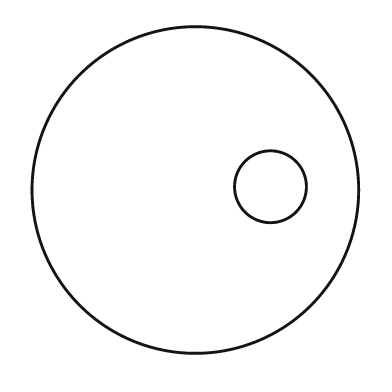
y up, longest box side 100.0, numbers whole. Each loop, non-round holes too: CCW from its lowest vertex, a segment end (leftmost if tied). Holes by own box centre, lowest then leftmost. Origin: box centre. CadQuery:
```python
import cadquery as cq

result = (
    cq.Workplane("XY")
    .moveTo(0.0, 0.0)
    .circle(50.0)
    .moveTo(23.0, 1.0)
    .circle(11.0)
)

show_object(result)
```